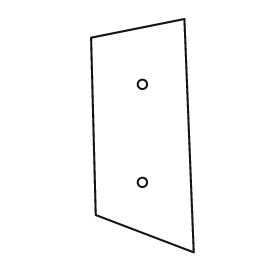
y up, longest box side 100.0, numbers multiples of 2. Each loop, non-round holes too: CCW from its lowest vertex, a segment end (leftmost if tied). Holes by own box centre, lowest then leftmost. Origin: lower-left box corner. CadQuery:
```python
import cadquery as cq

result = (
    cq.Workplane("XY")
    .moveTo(44.0, 0.0)
    .lineTo(40.0, 100.0)
    .lineTo(0.0, 92.0)
    .lineTo(2.0, 16.0)
    .close()
    .moveTo(22.0, 30.0)
    .circle(2.0)
    .moveTo(22.0, 72.0)
    .circle(2.0)
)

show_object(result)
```